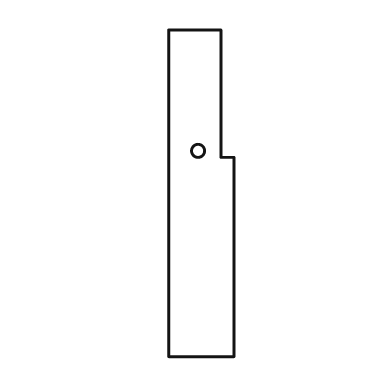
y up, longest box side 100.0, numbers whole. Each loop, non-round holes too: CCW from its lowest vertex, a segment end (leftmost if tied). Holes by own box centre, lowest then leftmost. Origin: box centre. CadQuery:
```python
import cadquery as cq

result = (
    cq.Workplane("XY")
    .moveTo(-10.0, -50.0)
    .lineTo(10.0, -50.0)
    .lineTo(10.0, 11.0)
    .lineTo(6.0, 11.0)
    .lineTo(6.0, 50.0)
    .lineTo(-10.0, 50.0)
    .close()
    .moveTo(-1.0, 13.0)
    .circle(2.0)
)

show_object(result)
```